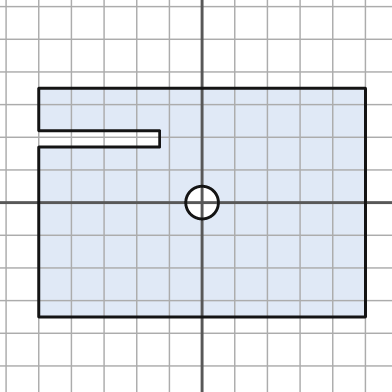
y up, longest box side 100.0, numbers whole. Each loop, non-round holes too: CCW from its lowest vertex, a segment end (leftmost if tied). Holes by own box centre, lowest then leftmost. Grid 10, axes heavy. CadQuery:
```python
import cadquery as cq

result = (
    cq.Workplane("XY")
    .moveTo(-50.0, -35.0)
    .lineTo(50.0, -35.0)
    .lineTo(50.0, 35.0)
    .lineTo(-50.0, 35.0)
    .lineTo(-50.0, 22.0)
    .lineTo(-13.0, 22.0)
    .lineTo(-13.0, 17.0)
    .lineTo(-50.0, 17.0)
    .close()
    .moveTo(0.0, 0.0)
    .circle(5.0)
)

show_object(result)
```